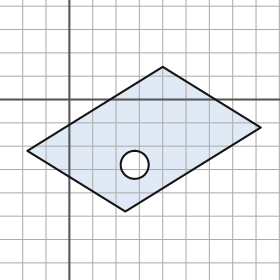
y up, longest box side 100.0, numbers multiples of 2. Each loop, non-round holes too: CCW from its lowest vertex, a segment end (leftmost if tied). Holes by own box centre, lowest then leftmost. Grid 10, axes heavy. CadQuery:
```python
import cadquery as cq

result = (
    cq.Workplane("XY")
    .moveTo(24.0, -48.0)
    .lineTo(82.0, -12.0)
    .lineTo(40.0, 14.0)
    .lineTo(-18.0, -22.0)
    .close()
    .moveTo(28.0, -28.0)
    .circle(6.0)
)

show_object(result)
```